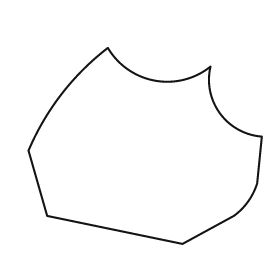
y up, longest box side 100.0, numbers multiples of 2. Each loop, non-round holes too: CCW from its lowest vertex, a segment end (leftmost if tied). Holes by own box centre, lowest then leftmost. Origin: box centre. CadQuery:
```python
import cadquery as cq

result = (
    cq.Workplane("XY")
    .moveTo(16.0, -42.0)
    .lineTo(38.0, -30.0)
    .threePointArc((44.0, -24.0), (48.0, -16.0))
    .lineTo(50.0, 4.0)
    .threePointArc((32.0, 14.0), (28.0, 34.0))
    .threePointArc((4.0, 28.0), (-16.0, 42.0))
    .threePointArc((-36.0, 22.0), (-50.0, -2.0))
    .lineTo(-42.0, -30.0)
    .close()
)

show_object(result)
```